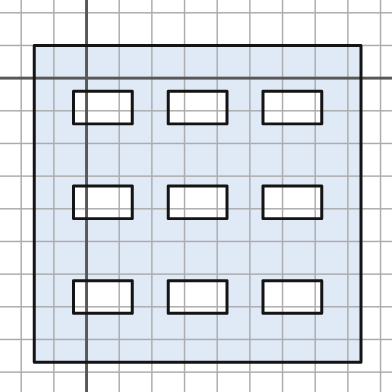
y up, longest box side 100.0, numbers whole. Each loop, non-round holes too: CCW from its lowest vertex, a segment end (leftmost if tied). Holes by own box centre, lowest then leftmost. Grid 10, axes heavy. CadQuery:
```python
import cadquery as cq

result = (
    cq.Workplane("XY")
    .moveTo(-16.0, -87.0)
    .lineTo(84.0, -87.0)
    .lineTo(84.0, 10.0)
    .lineTo(-16.0, 10.0)
    .close()
    .moveTo(-4.0, -72.0)
    .lineTo(14.0, -72.0)
    .lineTo(14.0, -62.0)
    .lineTo(-4.0, -62.0)
    .close()
    .moveTo(25.0, -72.0)
    .lineTo(43.0, -72.0)
    .lineTo(43.0, -62.0)
    .lineTo(25.0, -62.0)
    .close()
    .moveTo(54.0, -72.0)
    .lineTo(72.0, -72.0)
    .lineTo(72.0, -62.0)
    .lineTo(54.0, -62.0)
    .close()
    .moveTo(-4.0, -43.0)
    .lineTo(14.0, -43.0)
    .lineTo(14.0, -33.0)
    .lineTo(-4.0, -33.0)
    .close()
    .moveTo(25.0, -43.0)
    .lineTo(43.0, -43.0)
    .lineTo(43.0, -33.0)
    .lineTo(25.0, -33.0)
    .close()
    .moveTo(54.0, -43.0)
    .lineTo(72.0, -43.0)
    .lineTo(72.0, -33.0)
    .lineTo(54.0, -33.0)
    .close()
    .moveTo(-4.0, -14.0)
    .lineTo(14.0, -14.0)
    .lineTo(14.0, -4.0)
    .lineTo(-4.0, -4.0)
    .close()
    .moveTo(25.0, -14.0)
    .lineTo(43.0, -14.0)
    .lineTo(43.0, -4.0)
    .lineTo(25.0, -4.0)
    .close()
    .moveTo(54.0, -14.0)
    .lineTo(72.0, -14.0)
    .lineTo(72.0, -4.0)
    .lineTo(54.0, -4.0)
    .close()
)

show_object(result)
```